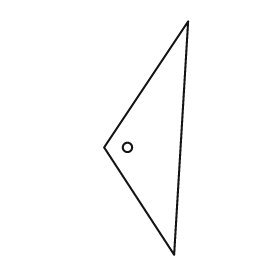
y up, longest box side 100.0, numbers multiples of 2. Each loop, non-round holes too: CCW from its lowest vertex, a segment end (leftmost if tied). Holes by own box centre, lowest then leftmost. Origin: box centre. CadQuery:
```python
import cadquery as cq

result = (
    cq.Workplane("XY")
    .moveTo(12.0, -50.0)
    .lineTo(18.0, 50.0)
    .lineTo(-18.0, -4.0)
    .close()
    .moveTo(-8.0, -4.0)
    .circle(2.0)
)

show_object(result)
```